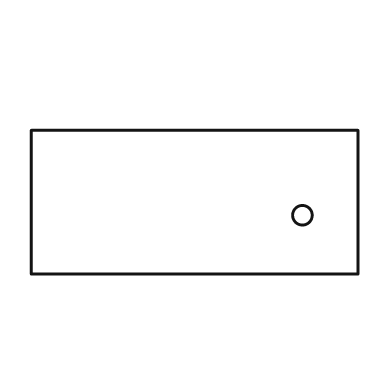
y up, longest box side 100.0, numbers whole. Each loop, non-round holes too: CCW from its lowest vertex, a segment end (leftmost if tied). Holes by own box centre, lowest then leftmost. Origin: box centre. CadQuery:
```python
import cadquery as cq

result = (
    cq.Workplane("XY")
    .moveTo(-50.0, -22.0)
    .lineTo(50.0, -22.0)
    .lineTo(50.0, 22.0)
    .lineTo(-50.0, 22.0)
    .close()
    .moveTo(33.0, -4.0)
    .circle(3.0)
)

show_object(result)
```